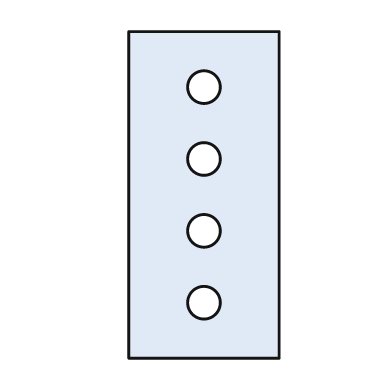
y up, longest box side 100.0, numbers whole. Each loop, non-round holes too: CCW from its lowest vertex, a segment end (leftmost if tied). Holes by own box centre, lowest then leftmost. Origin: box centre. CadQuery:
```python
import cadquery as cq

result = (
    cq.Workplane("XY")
    .moveTo(-23.0, -50.0)
    .lineTo(23.0, -50.0)
    .lineTo(23.0, 50.0)
    .lineTo(-23.0, 50.0)
    .close()
    .moveTo(0.0, -33.0)
    .circle(5.0)
    .moveTo(0.0, -11.0)
    .circle(5.0)
    .moveTo(0.0, 11.0)
    .circle(5.0)
    .moveTo(0.0, 33.0)
    .circle(5.0)
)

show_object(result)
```